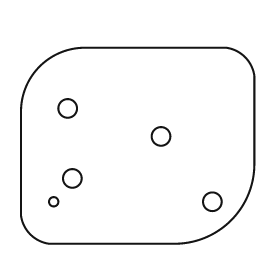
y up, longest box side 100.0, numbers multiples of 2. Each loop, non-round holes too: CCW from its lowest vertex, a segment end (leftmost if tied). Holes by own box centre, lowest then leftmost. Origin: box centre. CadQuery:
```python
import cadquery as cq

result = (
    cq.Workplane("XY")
    .moveTo(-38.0, -42.0)
    .lineTo(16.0, -42.0)
    .threePointArc((40.0, -32.0), (50.0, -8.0))
    .lineTo(50.0, 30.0)
    .threePointArc((46.0, 38.0), (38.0, 42.0))
    .lineTo(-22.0, 42.0)
    .threePointArc((-42.0, 34.0), (-50.0, 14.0))
    .lineTo(-50.0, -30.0)
    .threePointArc((-46.0, -38.0), (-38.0, -42.0))
    .close()
    .moveTo(-36.0, -24.0)
    .circle(2.0)
    .moveTo(32.0, -24.0)
    .circle(4.0)
    .moveTo(-28.0, -14.0)
    .circle(4.0)
    .moveTo(10.0, 4.0)
    .circle(4.0)
    .moveTo(-30.0, 16.0)
    .circle(4.0)
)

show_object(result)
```